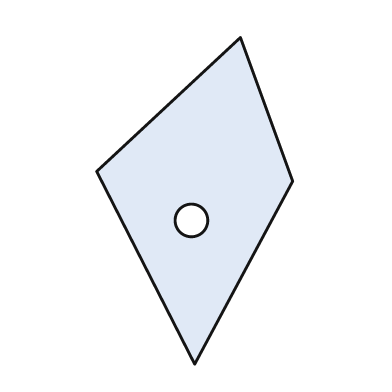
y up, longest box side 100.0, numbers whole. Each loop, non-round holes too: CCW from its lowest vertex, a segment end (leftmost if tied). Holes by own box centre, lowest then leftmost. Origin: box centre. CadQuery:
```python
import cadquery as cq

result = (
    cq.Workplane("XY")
    .moveTo(0.0, -50.0)
    .lineTo(30.0, 6.0)
    .lineTo(14.0, 50.0)
    .lineTo(-30.0, 9.0)
    .close()
    .moveTo(-1.0, -6.0)
    .circle(5.0)
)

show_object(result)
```